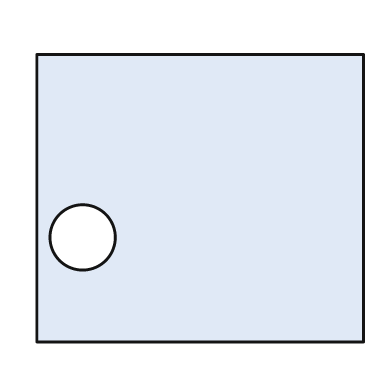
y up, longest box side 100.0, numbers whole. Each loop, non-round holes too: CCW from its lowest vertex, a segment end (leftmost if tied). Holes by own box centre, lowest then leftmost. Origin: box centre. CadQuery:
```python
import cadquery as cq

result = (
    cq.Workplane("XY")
    .moveTo(-50.0, -44.0)
    .lineTo(50.0, -44.0)
    .lineTo(50.0, 44.0)
    .lineTo(-50.0, 44.0)
    .close()
    .moveTo(-36.0, -12.0)
    .circle(10.0)
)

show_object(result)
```